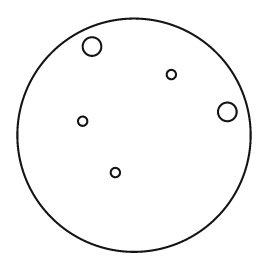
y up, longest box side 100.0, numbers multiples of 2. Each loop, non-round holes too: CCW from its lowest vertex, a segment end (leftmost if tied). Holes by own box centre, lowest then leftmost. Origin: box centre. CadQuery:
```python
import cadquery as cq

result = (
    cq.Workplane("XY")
    .moveTo(0.0, 0.0)
    .circle(50.0)
    .moveTo(-8.0, -16.0)
    .circle(2.0)
    .moveTo(-22.0, 6.0)
    .circle(2.0)
    .moveTo(40.0, 10.0)
    .circle(4.0)
    .moveTo(16.0, 26.0)
    .circle(2.0)
    .moveTo(-18.0, 38.0)
    .circle(4.0)
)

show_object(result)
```